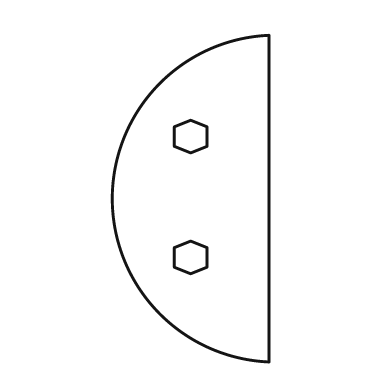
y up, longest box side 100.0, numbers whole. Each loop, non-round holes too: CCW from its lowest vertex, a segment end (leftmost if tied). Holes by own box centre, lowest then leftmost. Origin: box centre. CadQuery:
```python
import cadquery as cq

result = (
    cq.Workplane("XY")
    .moveTo(24.0, -50.0)
    .lineTo(24.0, 50.0)
    .threePointArc((-24.0, 0.0), (24.0, -50.0))
    .close()
    .moveTo(0.0, -23.0)
    .lineTo(5.0, -21.0)
    .lineTo(5.0, -15.0)
    .lineTo(0.0, -13.0)
    .lineTo(-5.0, -15.0)
    .lineTo(-5.0, -21.0)
    .close()
    .moveTo(0.0, 14.0)
    .lineTo(5.0, 16.0)
    .lineTo(5.0, 22.0)
    .lineTo(0.0, 24.0)
    .lineTo(-5.0, 22.0)
    .lineTo(-5.0, 16.0)
    .close()
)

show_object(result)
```